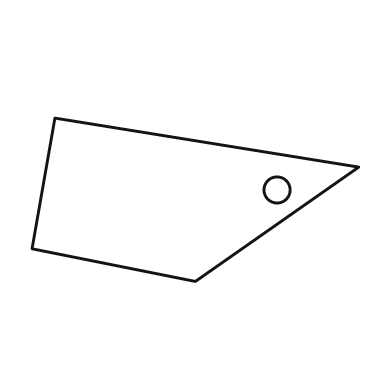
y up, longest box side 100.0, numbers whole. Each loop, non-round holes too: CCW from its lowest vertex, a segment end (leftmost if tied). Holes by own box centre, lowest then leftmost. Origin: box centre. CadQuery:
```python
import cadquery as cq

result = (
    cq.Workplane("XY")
    .moveTo(0.0, -25.0)
    .lineTo(50.0, 10.0)
    .lineTo(-43.0, 25.0)
    .lineTo(-50.0, -15.0)
    .close()
    .moveTo(25.0, 3.0)
    .circle(4.0)
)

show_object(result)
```